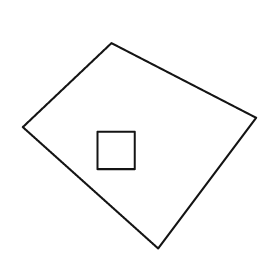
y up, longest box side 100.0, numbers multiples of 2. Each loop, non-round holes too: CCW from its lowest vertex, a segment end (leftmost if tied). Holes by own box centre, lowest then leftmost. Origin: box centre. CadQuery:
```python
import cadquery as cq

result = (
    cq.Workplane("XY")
    .moveTo(8.0, -44.0)
    .lineTo(50.0, 12.0)
    .lineTo(-12.0, 44.0)
    .lineTo(-50.0, 8.0)
    .close()
    .moveTo(-18.0, -10.0)
    .lineTo(-2.0, -10.0)
    .lineTo(-2.0, 6.0)
    .lineTo(-18.0, 6.0)
    .close()
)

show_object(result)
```